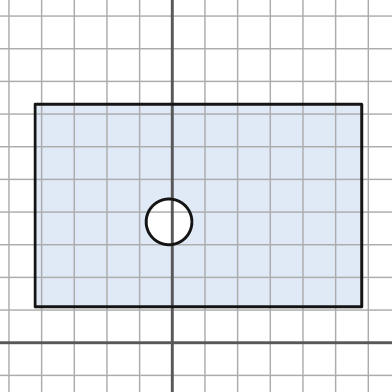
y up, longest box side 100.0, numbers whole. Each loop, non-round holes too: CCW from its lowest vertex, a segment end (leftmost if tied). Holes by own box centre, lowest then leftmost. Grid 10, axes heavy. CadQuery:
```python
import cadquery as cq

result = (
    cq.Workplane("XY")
    .moveTo(-42.0, 11.0)
    .lineTo(58.0, 11.0)
    .lineTo(58.0, 73.0)
    .lineTo(-42.0, 73.0)
    .close()
    .moveTo(-1.0, 37.0)
    .circle(7.0)
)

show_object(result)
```